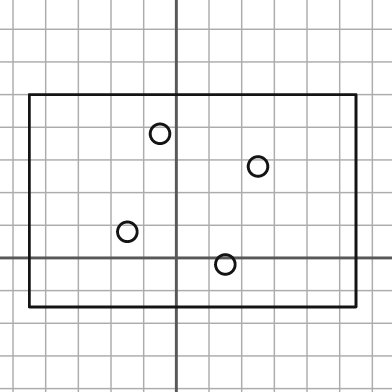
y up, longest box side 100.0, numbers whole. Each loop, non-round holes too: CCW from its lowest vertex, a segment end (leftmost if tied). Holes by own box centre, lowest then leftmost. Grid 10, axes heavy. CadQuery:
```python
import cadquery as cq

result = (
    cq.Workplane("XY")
    .moveTo(-45.0, -15.0)
    .lineTo(55.0, -15.0)
    .lineTo(55.0, 50.0)
    .lineTo(-45.0, 50.0)
    .close()
    .moveTo(15.0, -2.0)
    .circle(3.0)
    .moveTo(-15.0, 8.0)
    .circle(3.0)
    .moveTo(25.0, 28.0)
    .circle(3.0)
    .moveTo(-5.0, 38.0)
    .circle(3.0)
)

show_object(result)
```